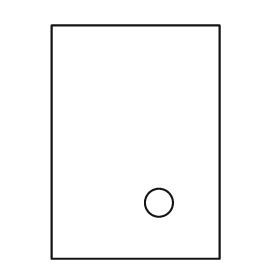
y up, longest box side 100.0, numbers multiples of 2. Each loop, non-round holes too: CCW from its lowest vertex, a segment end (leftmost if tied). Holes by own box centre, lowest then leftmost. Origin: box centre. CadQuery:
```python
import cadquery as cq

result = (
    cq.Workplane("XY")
    .moveTo(-36.0, -50.0)
    .lineTo(36.0, -50.0)
    .lineTo(36.0, 50.0)
    .lineTo(-36.0, 50.0)
    .close()
    .moveTo(10.0, -26.0)
    .circle(6.0)
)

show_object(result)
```